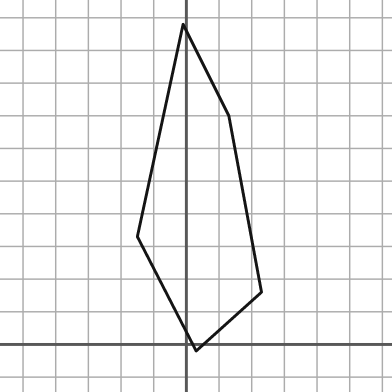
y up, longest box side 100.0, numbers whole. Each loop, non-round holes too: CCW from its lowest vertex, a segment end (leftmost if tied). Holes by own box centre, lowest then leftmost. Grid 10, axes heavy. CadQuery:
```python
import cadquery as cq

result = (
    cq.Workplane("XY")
    .moveTo(3.0, -2.0)
    .lineTo(23.0, 16.0)
    .lineTo(13.0, 70.0)
    .lineTo(-1.0, 98.0)
    .lineTo(-15.0, 33.0)
    .close()
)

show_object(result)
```